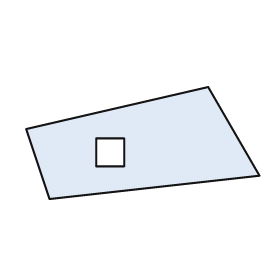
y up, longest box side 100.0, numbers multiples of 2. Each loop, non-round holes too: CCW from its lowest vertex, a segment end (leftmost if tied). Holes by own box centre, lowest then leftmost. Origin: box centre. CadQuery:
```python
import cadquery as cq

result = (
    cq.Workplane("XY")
    .moveTo(-40.0, -24.0)
    .lineTo(50.0, -14.0)
    .lineTo(28.0, 24.0)
    .lineTo(-50.0, 6.0)
    .close()
    .moveTo(-20.0, -10.0)
    .lineTo(-8.0, -10.0)
    .lineTo(-8.0, 2.0)
    .lineTo(-20.0, 2.0)
    .close()
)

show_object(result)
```